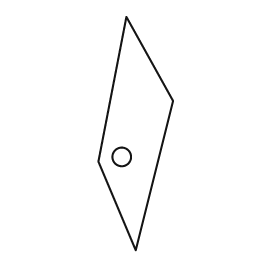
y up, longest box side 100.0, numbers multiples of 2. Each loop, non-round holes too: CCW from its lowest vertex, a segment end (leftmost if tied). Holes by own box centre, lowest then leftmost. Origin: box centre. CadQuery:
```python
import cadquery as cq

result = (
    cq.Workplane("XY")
    .moveTo(0.0, -50.0)
    .lineTo(16.0, 14.0)
    .lineTo(-4.0, 50.0)
    .lineTo(-16.0, -12.0)
    .close()
    .moveTo(-6.0, -10.0)
    .circle(4.0)
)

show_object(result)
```